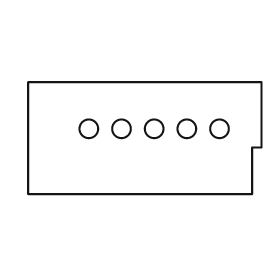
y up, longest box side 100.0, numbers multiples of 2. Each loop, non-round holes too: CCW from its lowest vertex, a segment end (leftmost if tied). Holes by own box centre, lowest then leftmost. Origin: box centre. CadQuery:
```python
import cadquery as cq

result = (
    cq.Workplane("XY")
    .moveTo(-50.0, -24.0)
    .lineTo(46.0, -24.0)
    .lineTo(46.0, -4.0)
    .lineTo(50.0, -4.0)
    .lineTo(50.0, 24.0)
    .lineTo(-50.0, 24.0)
    .close()
    .moveTo(-24.0, 4.0)
    .circle(4.0)
    .moveTo(-10.0, 4.0)
    .circle(4.0)
    .moveTo(4.0, 4.0)
    .circle(4.0)
    .moveTo(18.0, 4.0)
    .circle(4.0)
    .moveTo(32.0, 4.0)
    .circle(4.0)
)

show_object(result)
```